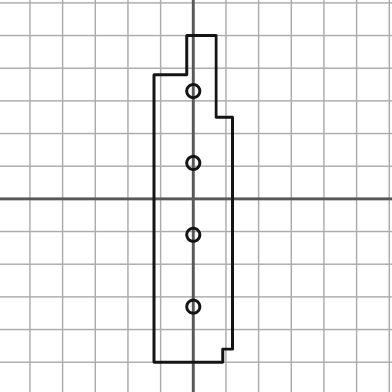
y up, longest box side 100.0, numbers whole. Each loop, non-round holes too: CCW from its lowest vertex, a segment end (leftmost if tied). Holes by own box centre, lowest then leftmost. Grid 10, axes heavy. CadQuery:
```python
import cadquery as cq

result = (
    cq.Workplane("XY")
    .moveTo(-12.0, -50.0)
    .lineTo(9.0, -50.0)
    .lineTo(9.0, -46.0)
    .lineTo(12.0, -46.0)
    .lineTo(12.0, 25.0)
    .lineTo(7.0, 25.0)
    .lineTo(7.0, 50.0)
    .lineTo(-2.0, 50.0)
    .lineTo(-2.0, 38.0)
    .lineTo(-12.0, 38.0)
    .close()
    .moveTo(0.0, -33.0)
    .circle(2.0)
    .moveTo(0.0, -11.0)
    .circle(2.0)
    .moveTo(0.0, 11.0)
    .circle(2.0)
    .moveTo(0.0, 33.0)
    .circle(2.0)
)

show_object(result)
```